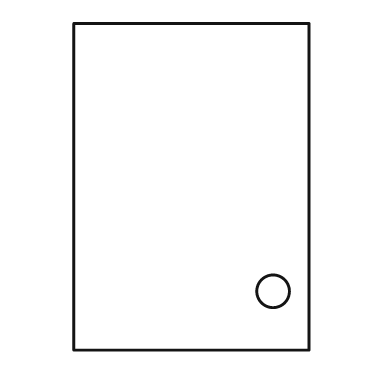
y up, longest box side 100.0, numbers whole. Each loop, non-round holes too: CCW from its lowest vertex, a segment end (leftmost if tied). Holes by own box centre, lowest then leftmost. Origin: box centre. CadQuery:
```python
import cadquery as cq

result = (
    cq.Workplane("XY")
    .moveTo(-36.0, -50.0)
    .lineTo(36.0, -50.0)
    .lineTo(36.0, 50.0)
    .lineTo(-36.0, 50.0)
    .close()
    .moveTo(25.0, -32.0)
    .circle(5.0)
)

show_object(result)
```